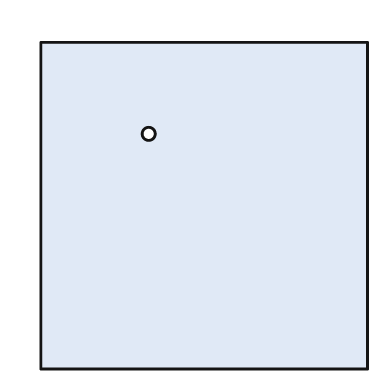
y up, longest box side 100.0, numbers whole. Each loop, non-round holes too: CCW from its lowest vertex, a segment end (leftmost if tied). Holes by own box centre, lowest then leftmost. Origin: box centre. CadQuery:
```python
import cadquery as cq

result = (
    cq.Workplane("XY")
    .moveTo(-50.0, -50.0)
    .lineTo(50.0, -50.0)
    .lineTo(50.0, 50.0)
    .lineTo(-50.0, 50.0)
    .close()
    .moveTo(-17.0, 22.0)
    .circle(2.0)
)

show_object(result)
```